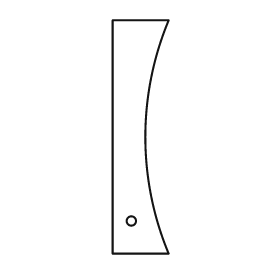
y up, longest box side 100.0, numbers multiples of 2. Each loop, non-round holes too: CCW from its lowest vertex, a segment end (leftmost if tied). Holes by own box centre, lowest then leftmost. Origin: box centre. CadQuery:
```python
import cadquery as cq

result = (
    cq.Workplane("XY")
    .moveTo(-12.0, -50.0)
    .lineTo(12.0, -50.0)
    .threePointArc((2.0, 0.0), (12.0, 50.0))
    .lineTo(-12.0, 50.0)
    .close()
    .moveTo(-4.0, -36.0)
    .circle(2.0)
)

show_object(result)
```